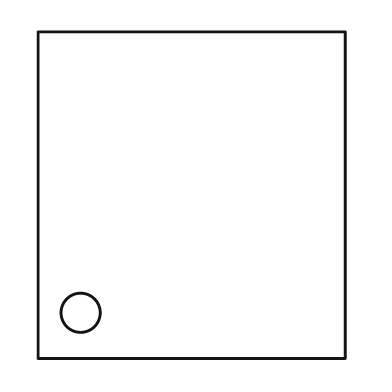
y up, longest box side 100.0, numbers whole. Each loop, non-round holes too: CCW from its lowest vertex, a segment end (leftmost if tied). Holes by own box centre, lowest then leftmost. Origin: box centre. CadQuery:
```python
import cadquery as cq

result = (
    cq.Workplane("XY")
    .moveTo(-47.0, -50.0)
    .lineTo(47.0, -50.0)
    .lineTo(47.0, 50.0)
    .lineTo(-47.0, 50.0)
    .close()
    .moveTo(-34.0, -36.0)
    .circle(6.0)
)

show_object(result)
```